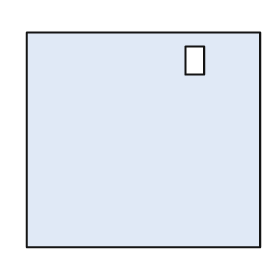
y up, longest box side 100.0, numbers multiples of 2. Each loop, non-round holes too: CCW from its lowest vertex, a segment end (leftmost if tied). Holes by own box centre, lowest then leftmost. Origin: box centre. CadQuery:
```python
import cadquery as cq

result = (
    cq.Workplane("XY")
    .moveTo(-50.0, -46.0)
    .lineTo(50.0, -46.0)
    .lineTo(50.0, 46.0)
    .lineTo(-50.0, 46.0)
    .close()
    .moveTo(18.0, 28.0)
    .lineTo(26.0, 28.0)
    .lineTo(26.0, 40.0)
    .lineTo(18.0, 40.0)
    .close()
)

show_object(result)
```